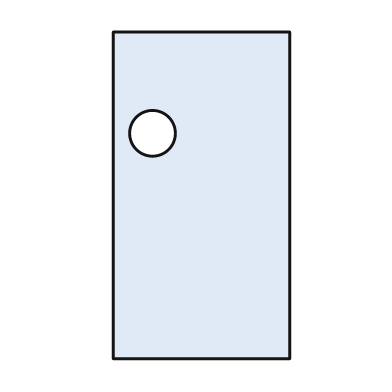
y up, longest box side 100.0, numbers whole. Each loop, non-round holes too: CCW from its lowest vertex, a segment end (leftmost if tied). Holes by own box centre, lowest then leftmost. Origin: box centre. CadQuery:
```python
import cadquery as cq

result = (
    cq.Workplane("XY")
    .moveTo(-27.0, -50.0)
    .lineTo(27.0, -50.0)
    .lineTo(27.0, 50.0)
    .lineTo(-27.0, 50.0)
    .close()
    .moveTo(-15.0, 19.0)
    .circle(7.0)
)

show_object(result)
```